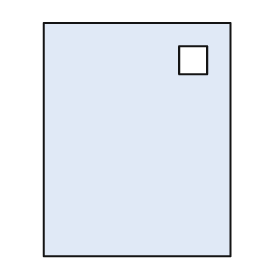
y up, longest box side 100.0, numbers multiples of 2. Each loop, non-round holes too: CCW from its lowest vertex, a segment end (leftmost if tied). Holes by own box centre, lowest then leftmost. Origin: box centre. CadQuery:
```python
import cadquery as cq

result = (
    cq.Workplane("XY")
    .moveTo(-40.0, -50.0)
    .lineTo(40.0, -50.0)
    .lineTo(40.0, 50.0)
    .lineTo(-40.0, 50.0)
    .close()
    .moveTo(18.0, 28.0)
    .lineTo(30.0, 28.0)
    .lineTo(30.0, 40.0)
    .lineTo(18.0, 40.0)
    .close()
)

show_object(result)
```